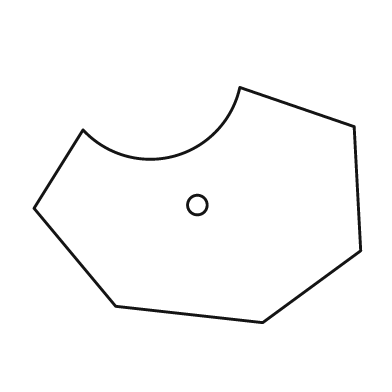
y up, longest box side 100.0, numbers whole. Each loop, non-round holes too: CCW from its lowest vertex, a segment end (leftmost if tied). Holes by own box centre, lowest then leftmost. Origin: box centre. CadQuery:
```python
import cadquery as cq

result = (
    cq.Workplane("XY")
    .moveTo(20.0, -36.0)
    .lineTo(50.0, -14.0)
    .lineTo(48.0, 24.0)
    .lineTo(13.0, 36.0)
    .threePointArc((-7.0, 15.0), (-35.0, 23.0))
    .lineTo(-50.0, -1.0)
    .lineTo(-25.0, -31.0)
    .close()
    .moveTo(0.0, 0.0)
    .circle(3.0)
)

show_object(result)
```